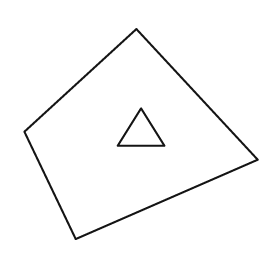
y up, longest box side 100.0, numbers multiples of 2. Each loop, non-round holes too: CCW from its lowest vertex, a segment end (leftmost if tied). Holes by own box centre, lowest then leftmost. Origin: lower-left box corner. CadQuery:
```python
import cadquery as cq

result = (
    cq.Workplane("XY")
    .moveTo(22.0, 0.0)
    .lineTo(100.0, 34.0)
    .lineTo(48.0, 90.0)
    .lineTo(0.0, 46.0)
    .close()
    .moveTo(40.0, 40.0)
    .lineTo(60.0, 40.0)
    .lineTo(50.0, 56.0)
    .close()
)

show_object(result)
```